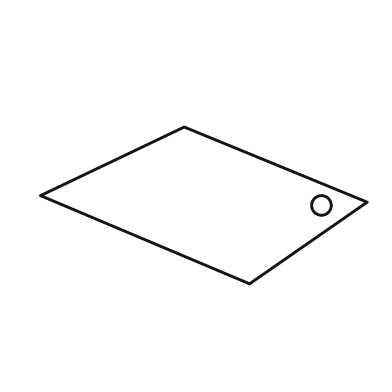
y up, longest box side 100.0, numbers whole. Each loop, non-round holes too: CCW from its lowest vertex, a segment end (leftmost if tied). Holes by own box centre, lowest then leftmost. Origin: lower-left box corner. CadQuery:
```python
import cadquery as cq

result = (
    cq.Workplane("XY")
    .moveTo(64.0, 0.0)
    .lineTo(100.0, 25.0)
    .lineTo(44.0, 48.0)
    .lineTo(0.0, 27.0)
    .close()
    .moveTo(86.0, 24.0)
    .circle(3.0)
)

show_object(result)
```